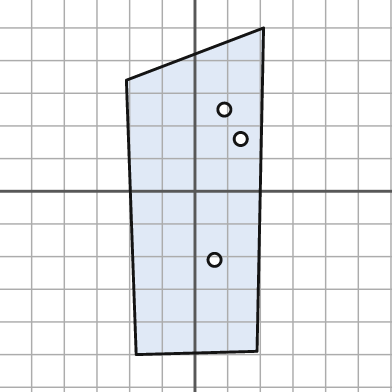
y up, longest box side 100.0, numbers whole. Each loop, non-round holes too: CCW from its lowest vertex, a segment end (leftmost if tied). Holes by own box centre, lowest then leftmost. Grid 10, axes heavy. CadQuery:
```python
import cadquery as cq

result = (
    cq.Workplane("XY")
    .moveTo(-18.0, -50.0)
    .lineTo(19.0, -49.0)
    .lineTo(21.0, 50.0)
    .lineTo(-21.0, 34.0)
    .close()
    .moveTo(6.0, -21.0)
    .circle(2.0)
    .moveTo(14.0, 16.0)
    .circle(2.0)
    .moveTo(9.0, 25.0)
    .circle(2.0)
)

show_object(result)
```